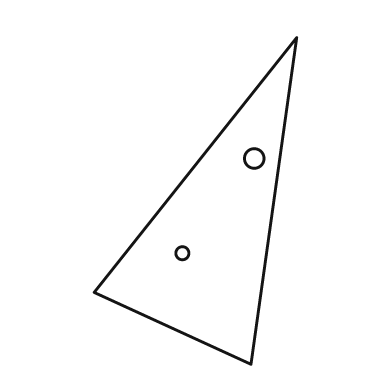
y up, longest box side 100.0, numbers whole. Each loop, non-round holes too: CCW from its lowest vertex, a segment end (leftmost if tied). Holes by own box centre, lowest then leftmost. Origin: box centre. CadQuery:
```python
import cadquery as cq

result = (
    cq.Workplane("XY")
    .moveTo(17.0, -50.0)
    .lineTo(31.0, 50.0)
    .lineTo(-31.0, -28.0)
    .close()
    .moveTo(-4.0, -16.0)
    .circle(2.0)
    .moveTo(18.0, 13.0)
    .circle(3.0)
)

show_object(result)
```